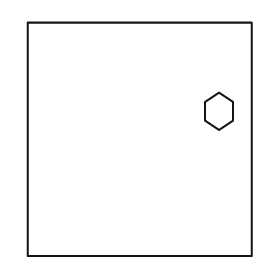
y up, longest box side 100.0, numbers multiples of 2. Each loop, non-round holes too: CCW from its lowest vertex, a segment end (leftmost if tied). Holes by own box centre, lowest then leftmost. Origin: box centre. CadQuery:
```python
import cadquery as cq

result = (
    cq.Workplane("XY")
    .moveTo(-48.0, -50.0)
    .lineTo(48.0, -50.0)
    .lineTo(48.0, 50.0)
    .lineTo(-48.0, 50.0)
    .close()
    .moveTo(34.0, 4.0)
    .lineTo(40.0, 8.0)
    .lineTo(40.0, 16.0)
    .lineTo(34.0, 20.0)
    .lineTo(28.0, 16.0)
    .lineTo(28.0, 8.0)
    .close()
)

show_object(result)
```